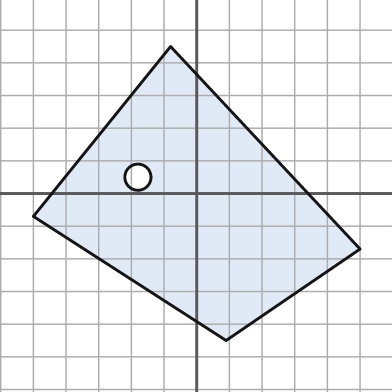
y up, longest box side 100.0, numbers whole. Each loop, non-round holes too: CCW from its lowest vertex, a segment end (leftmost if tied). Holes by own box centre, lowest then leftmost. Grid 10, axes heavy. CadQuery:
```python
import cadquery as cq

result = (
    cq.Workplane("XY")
    .moveTo(9.0, -45.0)
    .lineTo(50.0, -17.0)
    .lineTo(-8.0, 45.0)
    .lineTo(-50.0, -7.0)
    .close()
    .moveTo(-18.0, 5.0)
    .circle(4.0)
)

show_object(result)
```